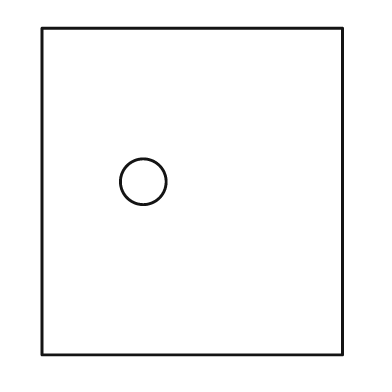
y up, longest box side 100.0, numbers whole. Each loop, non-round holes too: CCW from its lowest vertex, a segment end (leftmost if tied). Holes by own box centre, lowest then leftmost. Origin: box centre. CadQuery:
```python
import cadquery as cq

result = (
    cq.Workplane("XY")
    .moveTo(-46.0, -50.0)
    .lineTo(46.0, -50.0)
    .lineTo(46.0, 50.0)
    .lineTo(-46.0, 50.0)
    .close()
    .moveTo(-15.0, 3.0)
    .circle(7.0)
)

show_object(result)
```